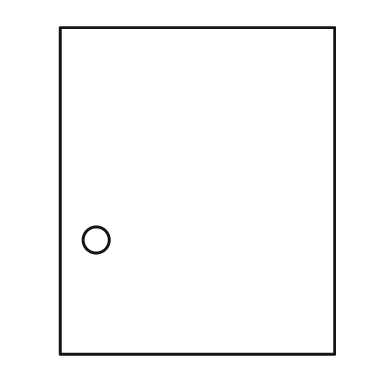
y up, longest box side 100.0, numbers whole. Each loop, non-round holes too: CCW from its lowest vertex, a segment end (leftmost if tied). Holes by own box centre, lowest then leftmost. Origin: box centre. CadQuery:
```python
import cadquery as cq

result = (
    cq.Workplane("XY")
    .moveTo(-42.0, -50.0)
    .lineTo(42.0, -50.0)
    .lineTo(42.0, 50.0)
    .lineTo(-42.0, 50.0)
    .close()
    .moveTo(-31.0, -15.0)
    .circle(4.0)
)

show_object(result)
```